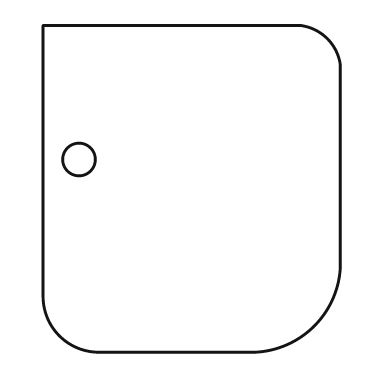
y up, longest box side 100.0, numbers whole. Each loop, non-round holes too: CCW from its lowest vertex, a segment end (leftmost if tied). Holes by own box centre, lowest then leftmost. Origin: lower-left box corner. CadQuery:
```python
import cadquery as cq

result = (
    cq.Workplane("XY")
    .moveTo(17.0, 0.0)
    .lineTo(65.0, 0.0)
    .threePointArc((83.0, 8.0), (91.0, 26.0))
    .lineTo(91.0, 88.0)
    .threePointArc((87.0, 96.0), (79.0, 100.0))
    .lineTo(0.0, 100.0)
    .lineTo(0.0, 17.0)
    .threePointArc((5.0, 5.0), (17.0, 0.0))
    .close()
    .moveTo(11.0, 59.0)
    .circle(5.0)
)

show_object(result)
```